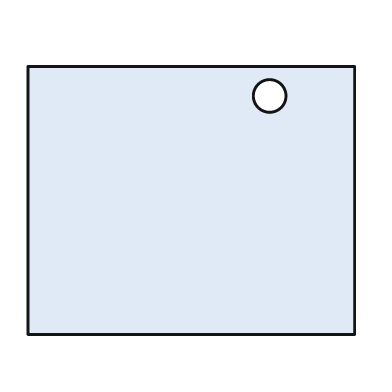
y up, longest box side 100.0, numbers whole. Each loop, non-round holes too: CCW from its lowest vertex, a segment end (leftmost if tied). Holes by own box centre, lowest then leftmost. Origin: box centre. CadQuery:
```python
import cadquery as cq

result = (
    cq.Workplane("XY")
    .moveTo(-50.0, -41.0)
    .lineTo(50.0, -41.0)
    .lineTo(50.0, 41.0)
    .lineTo(-50.0, 41.0)
    .close()
    .moveTo(24.0, 32.0)
    .circle(5.0)
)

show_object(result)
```